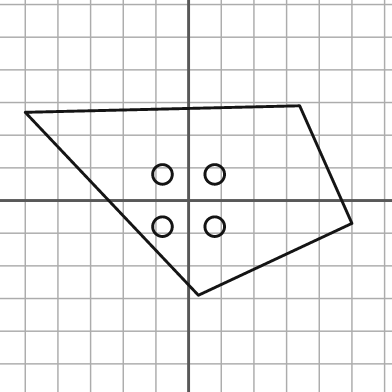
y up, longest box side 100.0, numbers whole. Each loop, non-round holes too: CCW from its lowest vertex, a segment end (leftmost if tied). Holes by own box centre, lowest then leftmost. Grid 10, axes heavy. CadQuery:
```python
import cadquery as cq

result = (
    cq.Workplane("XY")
    .moveTo(3.0, -29.0)
    .lineTo(50.0, -7.0)
    .lineTo(34.0, 29.0)
    .lineTo(-50.0, 27.0)
    .close()
    .moveTo(-8.0, -8.0)
    .circle(3.0)
    .moveTo(8.0, -8.0)
    .circle(3.0)
    .moveTo(-8.0, 8.0)
    .circle(3.0)
    .moveTo(8.0, 8.0)
    .circle(3.0)
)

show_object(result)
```